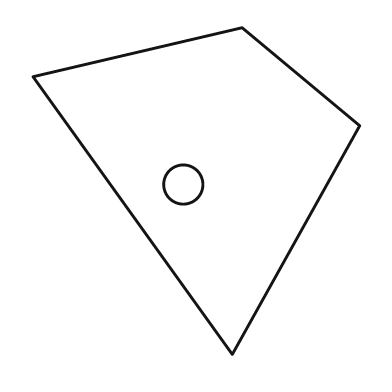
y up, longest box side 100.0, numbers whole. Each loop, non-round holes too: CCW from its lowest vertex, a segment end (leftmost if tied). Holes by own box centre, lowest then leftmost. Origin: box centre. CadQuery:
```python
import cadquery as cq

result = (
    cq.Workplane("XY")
    .moveTo(11.0, -50.0)
    .lineTo(50.0, 20.0)
    .lineTo(14.0, 50.0)
    .lineTo(-50.0, 35.0)
    .close()
    .moveTo(-4.0, 2.0)
    .circle(6.0)
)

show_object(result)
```